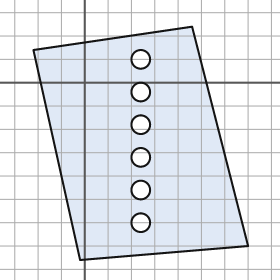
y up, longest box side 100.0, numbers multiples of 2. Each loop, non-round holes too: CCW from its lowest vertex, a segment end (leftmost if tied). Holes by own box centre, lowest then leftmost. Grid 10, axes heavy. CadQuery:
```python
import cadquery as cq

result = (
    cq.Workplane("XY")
    .moveTo(-2.0, -76.0)
    .lineTo(70.0, -70.0)
    .lineTo(46.0, 24.0)
    .lineTo(-22.0, 14.0)
    .close()
    .moveTo(24.0, -60.0)
    .circle(4.0)
    .moveTo(24.0, -46.0)
    .circle(4.0)
    .moveTo(24.0, -32.0)
    .circle(4.0)
    .moveTo(24.0, -18.0)
    .circle(4.0)
    .moveTo(24.0, -4.0)
    .circle(4.0)
    .moveTo(24.0, 10.0)
    .circle(4.0)
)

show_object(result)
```